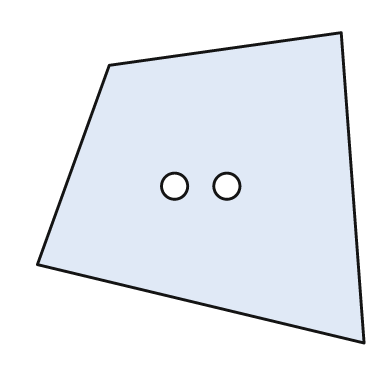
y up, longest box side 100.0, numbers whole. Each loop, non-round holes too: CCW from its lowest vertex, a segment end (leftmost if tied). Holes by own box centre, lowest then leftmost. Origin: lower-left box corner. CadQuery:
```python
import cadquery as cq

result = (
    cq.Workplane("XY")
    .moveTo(100.0, 0.0)
    .lineTo(93.0, 95.0)
    .lineTo(22.0, 85.0)
    .lineTo(0.0, 24.0)
    .close()
    .moveTo(42.0, 48.0)
    .circle(4.0)
    .moveTo(58.0, 48.0)
    .circle(4.0)
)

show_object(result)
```